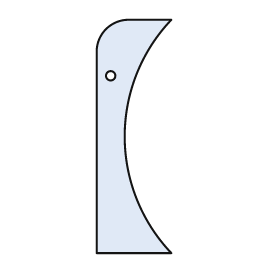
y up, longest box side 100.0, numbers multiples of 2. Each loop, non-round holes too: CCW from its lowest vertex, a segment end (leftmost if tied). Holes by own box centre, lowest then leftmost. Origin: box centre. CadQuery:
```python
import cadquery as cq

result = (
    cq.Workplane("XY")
    .moveTo(-16.0, -50.0)
    .lineTo(16.0, -50.0)
    .threePointArc((-4.0, 0.0), (16.0, 50.0))
    .lineTo(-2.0, 50.0)
    .threePointArc((-12.0, 46.0), (-16.0, 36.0))
    .close()
    .moveTo(-10.0, 26.0)
    .circle(2.0)
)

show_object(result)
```